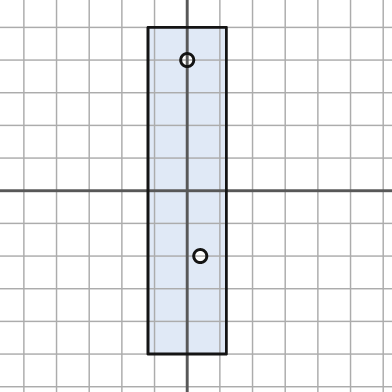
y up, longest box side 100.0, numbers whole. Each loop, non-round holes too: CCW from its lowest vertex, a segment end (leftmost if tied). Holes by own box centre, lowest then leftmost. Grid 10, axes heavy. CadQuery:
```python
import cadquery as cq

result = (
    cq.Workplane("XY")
    .moveTo(-12.0, -50.0)
    .lineTo(12.0, -50.0)
    .lineTo(12.0, 50.0)
    .lineTo(-12.0, 50.0)
    .close()
    .moveTo(4.0, -20.0)
    .circle(2.0)
    .moveTo(0.0, 40.0)
    .circle(2.0)
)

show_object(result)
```